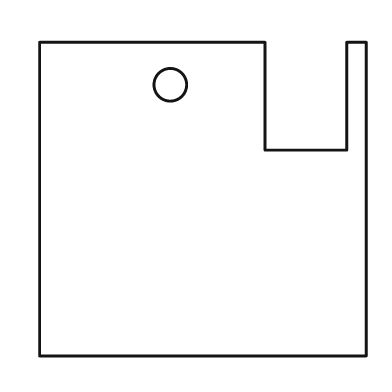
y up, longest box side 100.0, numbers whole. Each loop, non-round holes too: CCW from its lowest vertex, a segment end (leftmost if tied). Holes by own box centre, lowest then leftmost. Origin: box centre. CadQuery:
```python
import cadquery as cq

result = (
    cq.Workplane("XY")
    .moveTo(-50.0, -48.0)
    .lineTo(50.0, -48.0)
    .lineTo(50.0, 48.0)
    .lineTo(44.0, 48.0)
    .lineTo(44.0, 15.0)
    .lineTo(19.0, 15.0)
    .lineTo(19.0, 48.0)
    .lineTo(-50.0, 48.0)
    .close()
    .moveTo(-10.0, 35.0)
    .circle(5.0)
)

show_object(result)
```